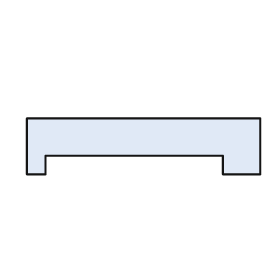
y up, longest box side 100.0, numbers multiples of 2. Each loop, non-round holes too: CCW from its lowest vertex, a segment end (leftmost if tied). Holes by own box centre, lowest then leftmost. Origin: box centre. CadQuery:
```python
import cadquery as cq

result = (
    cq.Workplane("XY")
    .moveTo(-50.0, -12.0)
    .lineTo(-42.0, -12.0)
    .lineTo(-42.0, -4.0)
    .lineTo(34.0, -4.0)
    .lineTo(34.0, -12.0)
    .lineTo(50.0, -12.0)
    .lineTo(50.0, 12.0)
    .lineTo(-50.0, 12.0)
    .close()
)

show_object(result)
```